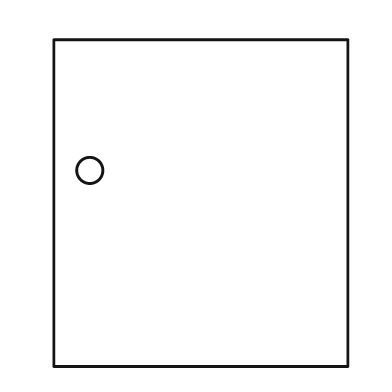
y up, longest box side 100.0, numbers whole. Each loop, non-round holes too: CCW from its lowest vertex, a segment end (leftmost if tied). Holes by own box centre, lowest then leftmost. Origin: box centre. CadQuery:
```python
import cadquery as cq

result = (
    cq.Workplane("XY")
    .moveTo(-45.0, -50.0)
    .lineTo(45.0, -50.0)
    .lineTo(45.0, 50.0)
    .lineTo(-45.0, 50.0)
    .close()
    .moveTo(-34.0, 10.0)
    .circle(4.0)
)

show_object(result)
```